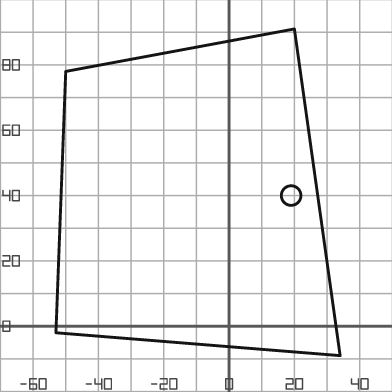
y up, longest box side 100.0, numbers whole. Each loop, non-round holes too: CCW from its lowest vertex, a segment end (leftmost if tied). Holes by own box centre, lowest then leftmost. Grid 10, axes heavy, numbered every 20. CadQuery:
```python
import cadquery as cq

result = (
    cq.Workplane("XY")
    .moveTo(34.0, -9.0)
    .lineTo(20.0, 91.0)
    .lineTo(-50.0, 78.0)
    .lineTo(-53.0, -2.0)
    .close()
    .moveTo(19.0, 40.0)
    .circle(3.0)
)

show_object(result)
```